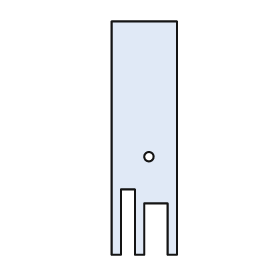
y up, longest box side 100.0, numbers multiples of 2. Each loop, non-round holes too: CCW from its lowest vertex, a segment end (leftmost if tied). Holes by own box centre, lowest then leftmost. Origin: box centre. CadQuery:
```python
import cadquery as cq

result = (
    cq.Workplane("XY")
    .moveTo(-14.0, -50.0)
    .lineTo(-10.0, -50.0)
    .lineTo(-10.0, -22.0)
    .lineTo(-4.0, -22.0)
    .lineTo(-4.0, -50.0)
    .lineTo(0.0, -50.0)
    .lineTo(0.0, -28.0)
    .lineTo(10.0, -28.0)
    .lineTo(10.0, -50.0)
    .lineTo(14.0, -50.0)
    .lineTo(14.0, 50.0)
    .lineTo(-14.0, 50.0)
    .close()
    .moveTo(2.0, -8.0)
    .circle(2.0)
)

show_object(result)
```